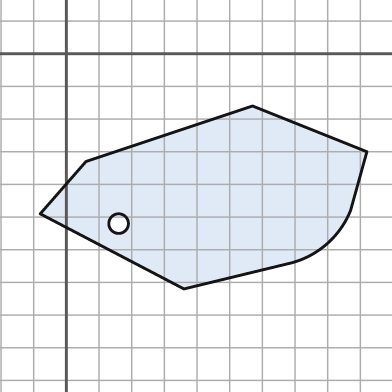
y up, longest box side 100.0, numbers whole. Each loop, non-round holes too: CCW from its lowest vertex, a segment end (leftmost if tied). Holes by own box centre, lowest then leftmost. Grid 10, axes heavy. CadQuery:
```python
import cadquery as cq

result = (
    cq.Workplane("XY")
    .moveTo(36.0, -72.0)
    .lineTo(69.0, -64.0)
    .threePointArc((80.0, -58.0), (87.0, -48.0))
    .lineTo(92.0, -30.0)
    .lineTo(57.0, -16.0)
    .lineTo(6.0, -33.0)
    .lineTo(-8.0, -49.0)
    .close()
    .moveTo(16.0, -52.0)
    .circle(3.0)
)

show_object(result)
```